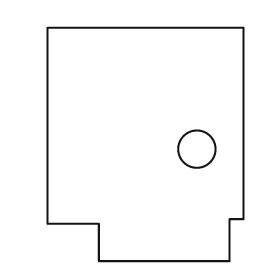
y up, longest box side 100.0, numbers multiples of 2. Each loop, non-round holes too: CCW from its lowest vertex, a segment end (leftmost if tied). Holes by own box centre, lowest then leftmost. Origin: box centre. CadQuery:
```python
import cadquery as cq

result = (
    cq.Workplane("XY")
    .moveTo(-20.0, -50.0)
    .lineTo(36.0, -50.0)
    .lineTo(36.0, -32.0)
    .lineTo(42.0, -32.0)
    .lineTo(42.0, 50.0)
    .lineTo(-42.0, 50.0)
    .lineTo(-42.0, -34.0)
    .lineTo(-20.0, -34.0)
    .close()
    .moveTo(22.0, -2.0)
    .circle(8.0)
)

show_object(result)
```